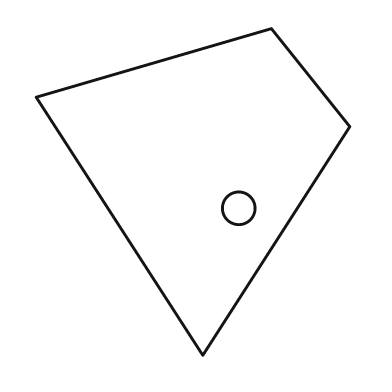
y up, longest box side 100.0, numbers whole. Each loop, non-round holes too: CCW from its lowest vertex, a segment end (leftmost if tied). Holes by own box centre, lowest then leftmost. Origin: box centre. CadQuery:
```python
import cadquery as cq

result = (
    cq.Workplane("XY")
    .moveTo(3.0, -50.0)
    .lineTo(48.0, 20.0)
    .lineTo(24.0, 50.0)
    .lineTo(-48.0, 29.0)
    .close()
    .moveTo(14.0, -5.0)
    .circle(5.0)
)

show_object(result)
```